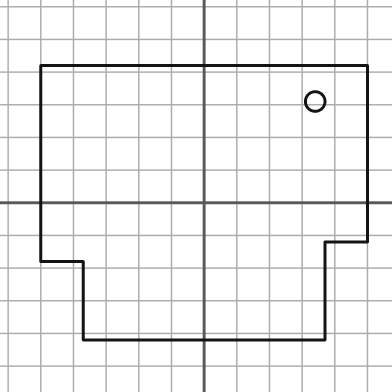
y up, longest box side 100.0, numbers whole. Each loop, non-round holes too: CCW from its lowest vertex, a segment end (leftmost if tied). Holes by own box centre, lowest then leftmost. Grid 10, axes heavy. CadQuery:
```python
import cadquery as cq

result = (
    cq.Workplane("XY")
    .moveTo(-37.0, -42.0)
    .lineTo(37.0, -42.0)
    .lineTo(37.0, -12.0)
    .lineTo(50.0, -12.0)
    .lineTo(50.0, 42.0)
    .lineTo(-50.0, 42.0)
    .lineTo(-50.0, -18.0)
    .lineTo(-37.0, -18.0)
    .close()
    .moveTo(34.0, 31.0)
    .circle(3.0)
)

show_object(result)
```